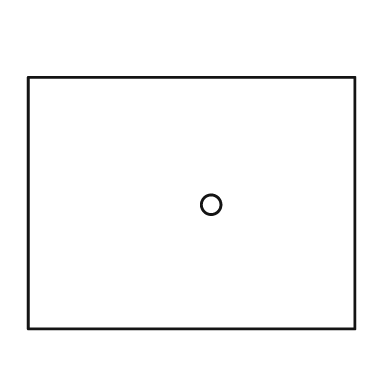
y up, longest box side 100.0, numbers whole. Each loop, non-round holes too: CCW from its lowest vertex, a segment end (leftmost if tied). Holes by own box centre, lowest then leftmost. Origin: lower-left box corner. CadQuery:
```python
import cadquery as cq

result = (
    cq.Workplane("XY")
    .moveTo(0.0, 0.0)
    .lineTo(100.0, 0.0)
    .lineTo(100.0, 77.0)
    .lineTo(0.0, 77.0)
    .close()
    .moveTo(56.0, 38.0)
    .circle(3.0)
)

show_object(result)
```